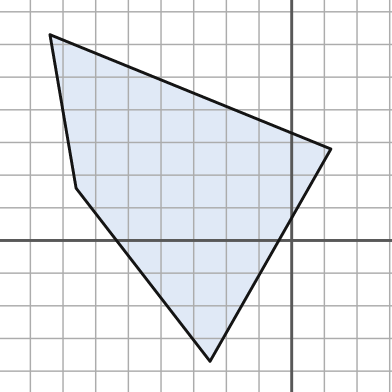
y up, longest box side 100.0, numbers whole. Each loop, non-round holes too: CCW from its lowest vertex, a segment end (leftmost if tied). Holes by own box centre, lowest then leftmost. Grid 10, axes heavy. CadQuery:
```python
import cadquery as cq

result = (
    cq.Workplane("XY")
    .moveTo(-25.0, -37.0)
    .lineTo(12.0, 28.0)
    .lineTo(-74.0, 63.0)
    .lineTo(-66.0, 16.0)
    .close()
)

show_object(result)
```